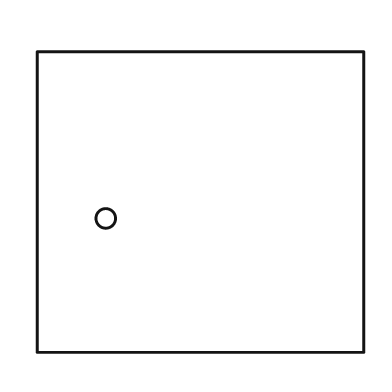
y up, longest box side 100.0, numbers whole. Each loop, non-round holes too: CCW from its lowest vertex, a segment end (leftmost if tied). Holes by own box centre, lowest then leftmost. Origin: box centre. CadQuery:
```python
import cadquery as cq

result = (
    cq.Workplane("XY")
    .moveTo(-50.0, -46.0)
    .lineTo(50.0, -46.0)
    .lineTo(50.0, 46.0)
    .lineTo(-50.0, 46.0)
    .close()
    .moveTo(-29.0, -5.0)
    .circle(3.0)
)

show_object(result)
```